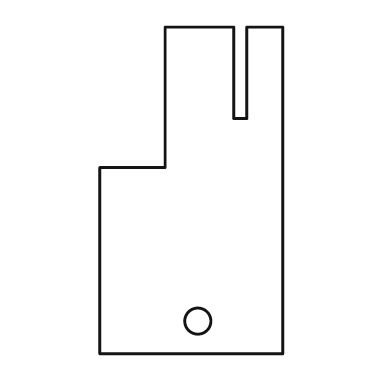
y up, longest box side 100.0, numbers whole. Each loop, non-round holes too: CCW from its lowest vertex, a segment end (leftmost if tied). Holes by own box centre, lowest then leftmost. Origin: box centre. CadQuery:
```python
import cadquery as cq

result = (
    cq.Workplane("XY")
    .moveTo(-28.0, -50.0)
    .lineTo(28.0, -50.0)
    .lineTo(28.0, 50.0)
    .lineTo(17.0, 50.0)
    .lineTo(17.0, 22.0)
    .lineTo(13.0, 22.0)
    .lineTo(13.0, 50.0)
    .lineTo(-8.0, 50.0)
    .lineTo(-8.0, 7.0)
    .lineTo(-28.0, 7.0)
    .close()
    .moveTo(2.0, -40.0)
    .circle(4.0)
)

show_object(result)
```